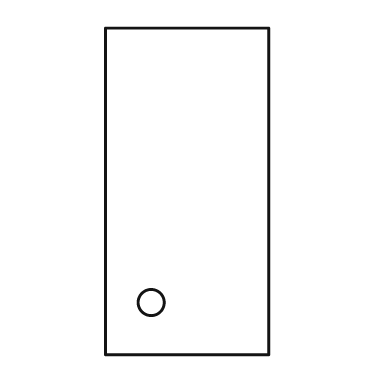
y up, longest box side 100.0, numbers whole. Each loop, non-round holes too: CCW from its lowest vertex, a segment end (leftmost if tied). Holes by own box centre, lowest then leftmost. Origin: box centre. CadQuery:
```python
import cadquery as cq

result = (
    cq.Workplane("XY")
    .moveTo(-25.0, -50.0)
    .lineTo(25.0, -50.0)
    .lineTo(25.0, 50.0)
    .lineTo(-25.0, 50.0)
    .close()
    .moveTo(-11.0, -34.0)
    .circle(4.0)
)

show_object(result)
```